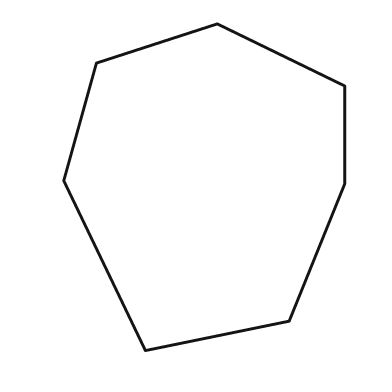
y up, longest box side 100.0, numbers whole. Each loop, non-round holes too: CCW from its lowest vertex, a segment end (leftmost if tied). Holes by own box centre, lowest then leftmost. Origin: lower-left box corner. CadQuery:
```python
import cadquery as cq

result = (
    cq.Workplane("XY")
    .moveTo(25.0, 0.0)
    .lineTo(69.0, 9.0)
    .lineTo(86.0, 51.0)
    .lineTo(86.0, 81.0)
    .lineTo(47.0, 100.0)
    .lineTo(10.0, 88.0)
    .lineTo(0.0, 52.0)
    .close()
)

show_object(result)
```